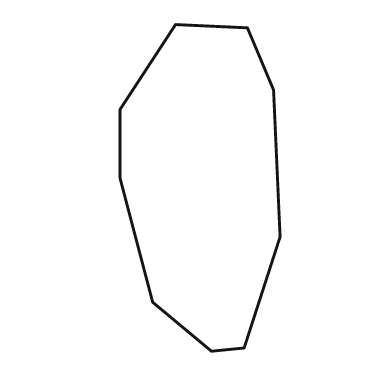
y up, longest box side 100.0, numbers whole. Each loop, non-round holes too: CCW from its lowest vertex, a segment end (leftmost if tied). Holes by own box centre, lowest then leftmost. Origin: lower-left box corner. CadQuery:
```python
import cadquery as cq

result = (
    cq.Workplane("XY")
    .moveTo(28.0, 0.0)
    .lineTo(38.0, 1.0)
    .lineTo(49.0, 35.0)
    .lineTo(47.0, 80.0)
    .lineTo(39.0, 99.0)
    .lineTo(17.0, 100.0)
    .lineTo(0.0, 74.0)
    .lineTo(0.0, 53.0)
    .lineTo(10.0, 15.0)
    .close()
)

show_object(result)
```